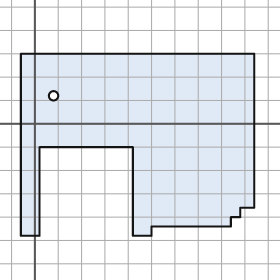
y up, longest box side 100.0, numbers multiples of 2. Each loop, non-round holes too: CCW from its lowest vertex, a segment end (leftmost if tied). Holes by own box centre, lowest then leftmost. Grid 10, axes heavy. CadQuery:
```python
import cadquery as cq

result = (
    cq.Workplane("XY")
    .moveTo(-6.0, -48.0)
    .lineTo(2.0, -48.0)
    .lineTo(2.0, -10.0)
    .lineTo(42.0, -10.0)
    .lineTo(42.0, -48.0)
    .lineTo(50.0, -48.0)
    .lineTo(50.0, -44.0)
    .lineTo(84.0, -44.0)
    .lineTo(84.0, -40.0)
    .lineTo(88.0, -40.0)
    .lineTo(88.0, -36.0)
    .lineTo(94.0, -36.0)
    .lineTo(94.0, 30.0)
    .lineTo(-6.0, 30.0)
    .close()
    .moveTo(8.0, 12.0)
    .circle(2.0)
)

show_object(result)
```